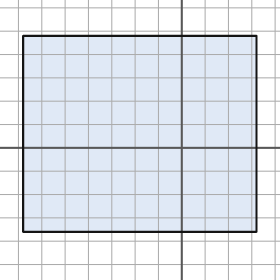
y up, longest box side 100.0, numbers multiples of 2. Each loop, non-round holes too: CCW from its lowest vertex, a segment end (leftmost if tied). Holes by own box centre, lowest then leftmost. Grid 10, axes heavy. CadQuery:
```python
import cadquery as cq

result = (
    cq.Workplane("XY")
    .moveTo(-68.0, -36.0)
    .lineTo(32.0, -36.0)
    .lineTo(32.0, 48.0)
    .lineTo(-68.0, 48.0)
    .close()
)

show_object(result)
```